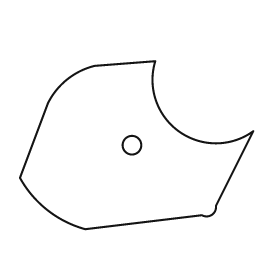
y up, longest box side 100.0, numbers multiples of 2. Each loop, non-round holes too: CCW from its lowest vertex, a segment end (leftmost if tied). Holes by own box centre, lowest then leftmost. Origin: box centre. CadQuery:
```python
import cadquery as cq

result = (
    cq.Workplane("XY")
    .moveTo(-22.0, -36.0)
    .lineTo(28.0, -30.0)
    .threePointArc((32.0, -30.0), (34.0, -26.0))
    .lineTo(50.0, 6.0)
    .threePointArc((18.0, 6.0), (8.0, 36.0))
    .lineTo(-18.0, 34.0)
    .threePointArc((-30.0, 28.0), (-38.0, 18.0))
    .lineTo(-50.0, -14.0)
    .threePointArc((-38.0, -28.0), (-22.0, -36.0))
    .close()
    .moveTo(-2.0, 0.0)
    .circle(4.0)
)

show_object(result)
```